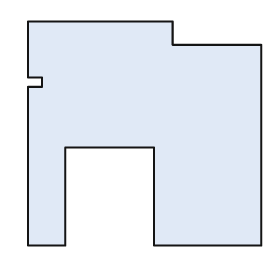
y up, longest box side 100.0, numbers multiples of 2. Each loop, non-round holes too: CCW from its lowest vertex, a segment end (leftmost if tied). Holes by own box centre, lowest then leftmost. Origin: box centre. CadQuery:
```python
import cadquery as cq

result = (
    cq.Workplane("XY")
    .moveTo(-50.0, -48.0)
    .lineTo(-34.0, -48.0)
    .lineTo(-34.0, -6.0)
    .lineTo(4.0, -6.0)
    .lineTo(4.0, -48.0)
    .lineTo(50.0, -48.0)
    .lineTo(50.0, 38.0)
    .lineTo(12.0, 38.0)
    .lineTo(12.0, 48.0)
    .lineTo(-50.0, 48.0)
    .lineTo(-50.0, 24.0)
    .lineTo(-44.0, 24.0)
    .lineTo(-44.0, 20.0)
    .lineTo(-50.0, 20.0)
    .close()
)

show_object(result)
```